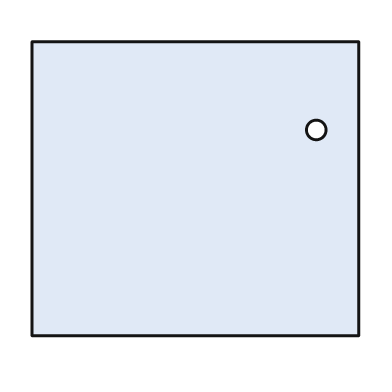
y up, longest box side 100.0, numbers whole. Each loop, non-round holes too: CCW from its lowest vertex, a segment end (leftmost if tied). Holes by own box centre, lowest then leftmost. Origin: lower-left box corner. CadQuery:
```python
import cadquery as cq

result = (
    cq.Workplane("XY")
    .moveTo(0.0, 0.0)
    .lineTo(100.0, 0.0)
    .lineTo(100.0, 90.0)
    .lineTo(0.0, 90.0)
    .close()
    .moveTo(87.0, 63.0)
    .circle(3.0)
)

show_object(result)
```